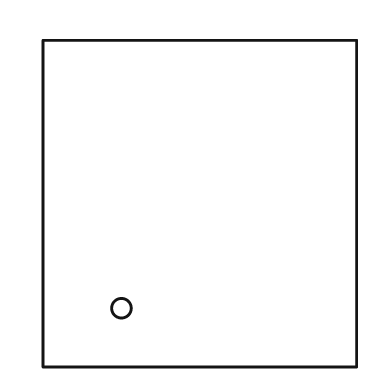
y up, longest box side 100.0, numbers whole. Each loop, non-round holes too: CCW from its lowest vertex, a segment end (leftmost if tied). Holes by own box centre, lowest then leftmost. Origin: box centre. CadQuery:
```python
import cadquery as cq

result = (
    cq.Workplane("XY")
    .moveTo(-48.0, -50.0)
    .lineTo(48.0, -50.0)
    .lineTo(48.0, 50.0)
    .lineTo(-48.0, 50.0)
    .close()
    .moveTo(-24.0, -32.0)
    .circle(3.0)
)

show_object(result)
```